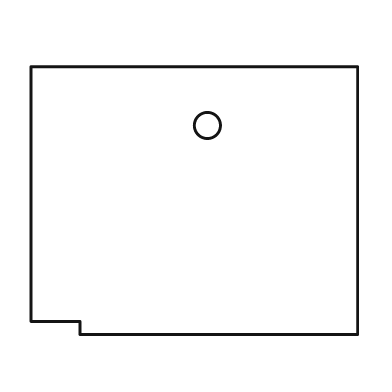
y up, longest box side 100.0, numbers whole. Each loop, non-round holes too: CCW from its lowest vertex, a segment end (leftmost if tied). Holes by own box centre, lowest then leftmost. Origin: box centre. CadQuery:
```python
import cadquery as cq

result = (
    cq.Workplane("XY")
    .moveTo(-35.0, -41.0)
    .lineTo(50.0, -41.0)
    .lineTo(50.0, 41.0)
    .lineTo(-50.0, 41.0)
    .lineTo(-50.0, -37.0)
    .lineTo(-35.0, -37.0)
    .close()
    .moveTo(4.0, 23.0)
    .circle(4.0)
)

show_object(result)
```